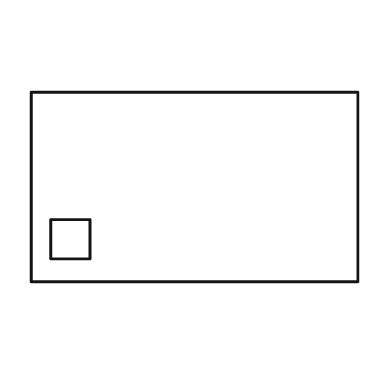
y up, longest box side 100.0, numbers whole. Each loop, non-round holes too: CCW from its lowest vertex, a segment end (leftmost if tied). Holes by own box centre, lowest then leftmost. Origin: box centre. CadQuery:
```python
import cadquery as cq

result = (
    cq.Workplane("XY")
    .moveTo(-50.0, -29.0)
    .lineTo(50.0, -29.0)
    .lineTo(50.0, 29.0)
    .lineTo(-50.0, 29.0)
    .close()
    .moveTo(-44.0, -22.0)
    .lineTo(-32.0, -22.0)
    .lineTo(-32.0, -10.0)
    .lineTo(-44.0, -10.0)
    .close()
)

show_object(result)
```